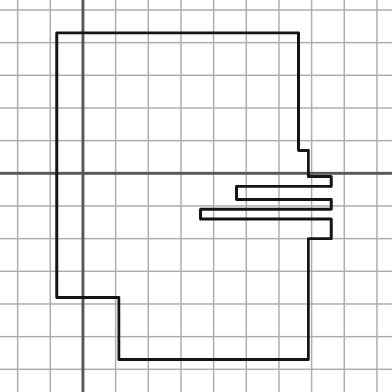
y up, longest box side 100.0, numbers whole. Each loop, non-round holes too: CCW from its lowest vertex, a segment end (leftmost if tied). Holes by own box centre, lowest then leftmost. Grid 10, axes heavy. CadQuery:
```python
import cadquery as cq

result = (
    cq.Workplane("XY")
    .moveTo(11.0, -57.0)
    .lineTo(69.0, -57.0)
    .lineTo(69.0, -20.0)
    .lineTo(76.0, -20.0)
    .lineTo(76.0, -14.0)
    .lineTo(36.0, -14.0)
    .lineTo(36.0, -11.0)
    .lineTo(76.0, -11.0)
    .lineTo(76.0, -8.0)
    .lineTo(47.0, -8.0)
    .lineTo(47.0, -4.0)
    .lineTo(76.0, -4.0)
    .lineTo(76.0, -1.0)
    .lineTo(69.0, -1.0)
    .lineTo(69.0, 7.0)
    .lineTo(66.0, 7.0)
    .lineTo(66.0, 43.0)
    .lineTo(-8.0, 43.0)
    .lineTo(-8.0, -38.0)
    .lineTo(11.0, -38.0)
    .close()
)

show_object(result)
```